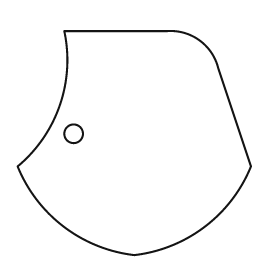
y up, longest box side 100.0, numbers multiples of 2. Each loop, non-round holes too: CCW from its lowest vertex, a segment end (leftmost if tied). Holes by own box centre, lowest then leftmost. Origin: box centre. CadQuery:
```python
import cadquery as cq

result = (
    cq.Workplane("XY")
    .moveTo(0.0, -48.0)
    .threePointArc((30.0, -36.0), (50.0, -10.0))
    .lineTo(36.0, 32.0)
    .threePointArc((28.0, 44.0), (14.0, 48.0))
    .lineTo(-30.0, 48.0)
    .threePointArc((-32.0, 16.0), (-50.0, -10.0))
    .threePointArc((-30.0, -36.0), (0.0, -48.0))
    .close()
    .moveTo(-26.0, 4.0)
    .circle(4.0)
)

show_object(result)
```